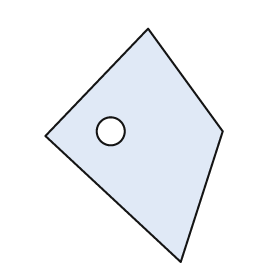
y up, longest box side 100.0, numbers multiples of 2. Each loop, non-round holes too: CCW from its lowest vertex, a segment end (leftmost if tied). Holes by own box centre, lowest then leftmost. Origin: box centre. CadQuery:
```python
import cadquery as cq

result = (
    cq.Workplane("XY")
    .moveTo(20.0, -50.0)
    .lineTo(38.0, 6.0)
    .lineTo(6.0, 50.0)
    .lineTo(-38.0, 4.0)
    .close()
    .moveTo(-10.0, 6.0)
    .circle(6.0)
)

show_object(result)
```